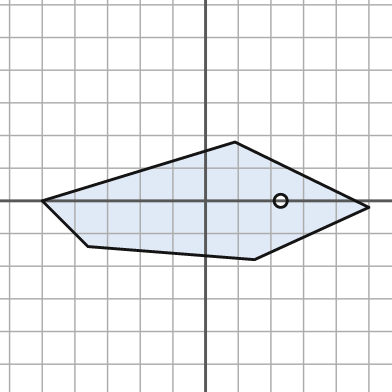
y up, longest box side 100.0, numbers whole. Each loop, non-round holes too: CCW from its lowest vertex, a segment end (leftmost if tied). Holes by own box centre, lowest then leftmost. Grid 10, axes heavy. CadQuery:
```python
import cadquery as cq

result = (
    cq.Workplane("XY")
    .moveTo(15.0, -18.0)
    .lineTo(50.0, -2.0)
    .lineTo(9.0, 18.0)
    .lineTo(-50.0, 0.0)
    .lineTo(-36.0, -14.0)
    .close()
    .moveTo(23.0, 0.0)
    .circle(2.0)
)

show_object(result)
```